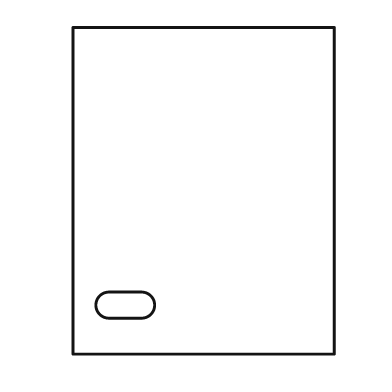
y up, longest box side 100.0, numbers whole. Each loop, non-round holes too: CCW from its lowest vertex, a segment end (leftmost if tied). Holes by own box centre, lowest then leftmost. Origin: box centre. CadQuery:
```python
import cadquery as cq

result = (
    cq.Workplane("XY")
    .moveTo(-40.0, -50.0)
    .lineTo(40.0, -50.0)
    .lineTo(40.0, 50.0)
    .lineTo(-40.0, 50.0)
    .close()
    .moveTo(-29.0, -39.0)
    .lineTo(-19.0, -39.0)
    .threePointArc((-15.0, -35.0), (-19.0, -31.0))
    .lineTo(-29.0, -31.0)
    .threePointArc((-33.0, -35.0), (-29.0, -39.0))
    .close()
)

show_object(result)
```